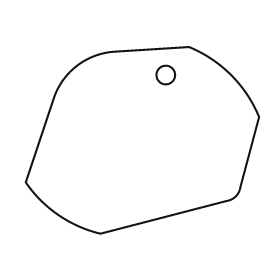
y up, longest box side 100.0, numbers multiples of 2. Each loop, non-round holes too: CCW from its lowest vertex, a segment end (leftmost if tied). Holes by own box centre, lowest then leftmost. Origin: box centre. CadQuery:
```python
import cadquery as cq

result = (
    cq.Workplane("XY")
    .moveTo(-18.0, -40.0)
    .lineTo(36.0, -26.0)
    .threePointArc((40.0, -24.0), (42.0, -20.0))
    .lineTo(50.0, 10.0)
    .threePointArc((38.0, 28.0), (20.0, 40.0))
    .lineTo(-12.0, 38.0)
    .threePointArc((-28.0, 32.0), (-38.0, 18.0))
    .lineTo(-50.0, -18.0)
    .threePointArc((-36.0, -32.0), (-18.0, -40.0))
    .close()
    .moveTo(10.0, 28.0)
    .circle(4.0)
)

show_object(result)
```